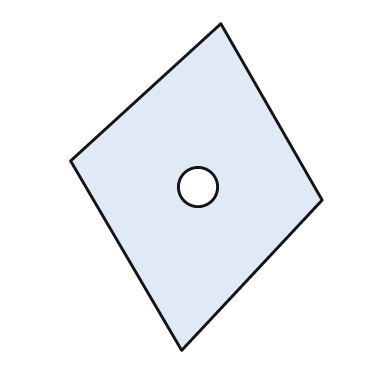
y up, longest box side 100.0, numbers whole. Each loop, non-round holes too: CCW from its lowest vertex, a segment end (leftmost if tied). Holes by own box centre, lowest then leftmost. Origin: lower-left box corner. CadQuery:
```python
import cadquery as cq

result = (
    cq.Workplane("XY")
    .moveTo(34.0, 0.0)
    .lineTo(77.0, 46.0)
    .lineTo(46.0, 100.0)
    .lineTo(0.0, 58.0)
    .close()
    .moveTo(39.0, 50.0)
    .circle(6.0)
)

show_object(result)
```